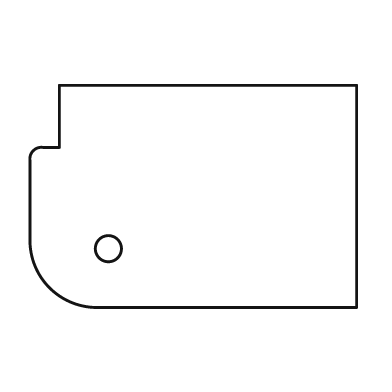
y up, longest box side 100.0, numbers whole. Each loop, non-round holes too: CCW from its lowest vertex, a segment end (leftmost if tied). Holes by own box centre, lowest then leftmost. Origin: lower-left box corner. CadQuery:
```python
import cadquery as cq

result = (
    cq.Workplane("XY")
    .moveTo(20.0, 0.0)
    .lineTo(100.0, 0.0)
    .lineTo(100.0, 68.0)
    .lineTo(9.0, 68.0)
    .lineTo(9.0, 49.0)
    .lineTo(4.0, 49.0)
    .threePointArc((1.0, 48.0), (0.0, 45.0))
    .lineTo(0.0, 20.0)
    .threePointArc((6.0, 6.0), (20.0, 0.0))
    .close()
    .moveTo(24.0, 18.0)
    .circle(4.0)
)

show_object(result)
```